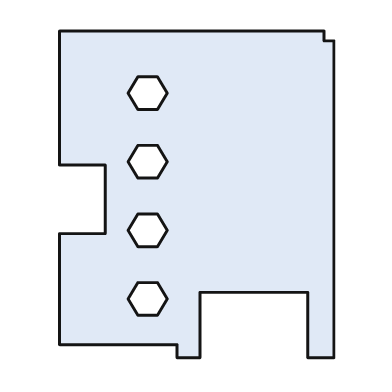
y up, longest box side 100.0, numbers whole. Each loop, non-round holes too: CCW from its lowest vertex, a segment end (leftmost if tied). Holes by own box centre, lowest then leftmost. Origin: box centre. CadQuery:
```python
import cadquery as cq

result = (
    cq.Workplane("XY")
    .moveTo(-6.0, -50.0)
    .lineTo(1.0, -50.0)
    .lineTo(1.0, -30.0)
    .lineTo(34.0, -30.0)
    .lineTo(34.0, -50.0)
    .lineTo(42.0, -50.0)
    .lineTo(42.0, 47.0)
    .lineTo(39.0, 47.0)
    .lineTo(39.0, 50.0)
    .lineTo(-42.0, 50.0)
    .lineTo(-42.0, 9.0)
    .lineTo(-28.0, 9.0)
    .lineTo(-28.0, -12.0)
    .lineTo(-42.0, -12.0)
    .lineTo(-42.0, -46.0)
    .lineTo(-6.0, -46.0)
    .close()
    .moveTo(-18.0, -37.0)
    .lineTo(-12.0, -37.0)
    .lineTo(-9.0, -32.0)
    .lineTo(-12.0, -27.0)
    .lineTo(-18.0, -27.0)
    .lineTo(-21.0, -32.0)
    .close()
    .moveTo(-18.0, -16.0)
    .lineTo(-12.0, -16.0)
    .lineTo(-9.0, -11.0)
    .lineTo(-12.0, -6.0)
    .lineTo(-18.0, -6.0)
    .lineTo(-21.0, -11.0)
    .close()
    .moveTo(-18.0, 5.0)
    .lineTo(-12.0, 5.0)
    .lineTo(-9.0, 10.0)
    .lineTo(-12.0, 15.0)
    .lineTo(-18.0, 15.0)
    .lineTo(-21.0, 10.0)
    .close()
    .moveTo(-18.0, 26.0)
    .lineTo(-12.0, 26.0)
    .lineTo(-9.0, 31.0)
    .lineTo(-12.0, 36.0)
    .lineTo(-18.0, 36.0)
    .lineTo(-21.0, 31.0)
    .close()
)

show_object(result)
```